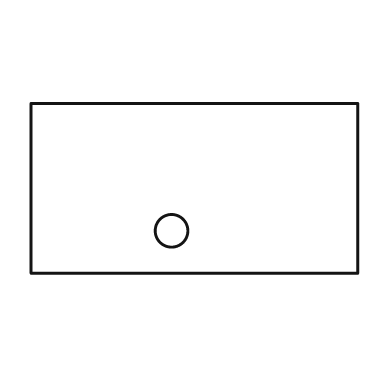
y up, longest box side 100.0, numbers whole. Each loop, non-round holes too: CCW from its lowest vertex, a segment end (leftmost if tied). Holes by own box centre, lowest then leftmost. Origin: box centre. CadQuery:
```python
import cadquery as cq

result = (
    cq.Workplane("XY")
    .moveTo(-50.0, -26.0)
    .lineTo(50.0, -26.0)
    .lineTo(50.0, 26.0)
    .lineTo(-50.0, 26.0)
    .close()
    .moveTo(-7.0, -13.0)
    .circle(5.0)
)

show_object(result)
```